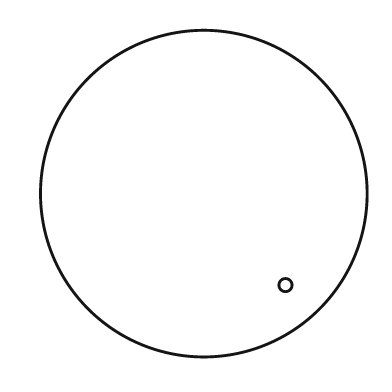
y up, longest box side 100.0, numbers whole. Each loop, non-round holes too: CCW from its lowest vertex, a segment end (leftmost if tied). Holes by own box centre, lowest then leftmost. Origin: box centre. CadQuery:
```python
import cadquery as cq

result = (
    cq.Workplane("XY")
    .moveTo(0.0, 0.0)
    .circle(50.0)
    .moveTo(25.0, -28.0)
    .circle(2.0)
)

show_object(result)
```